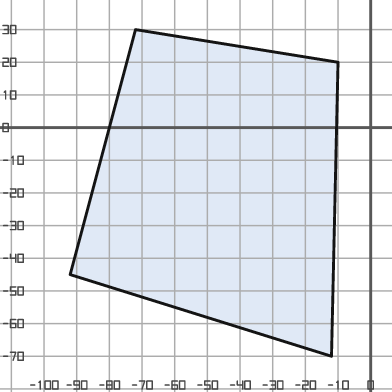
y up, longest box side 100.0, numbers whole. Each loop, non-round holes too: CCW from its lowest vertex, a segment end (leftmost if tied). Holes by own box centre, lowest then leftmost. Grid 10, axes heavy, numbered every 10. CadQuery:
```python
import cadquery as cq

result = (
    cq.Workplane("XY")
    .moveTo(-12.0, -70.0)
    .lineTo(-10.0, 20.0)
    .lineTo(-72.0, 30.0)
    .lineTo(-92.0, -45.0)
    .close()
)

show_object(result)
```